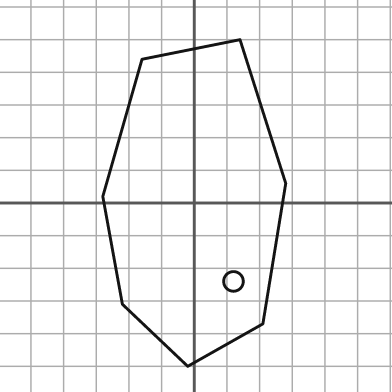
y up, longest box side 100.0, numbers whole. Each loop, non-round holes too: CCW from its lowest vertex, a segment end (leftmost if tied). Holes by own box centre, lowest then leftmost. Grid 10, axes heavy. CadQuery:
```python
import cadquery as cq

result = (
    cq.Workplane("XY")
    .moveTo(-2.0, -50.0)
    .lineTo(21.0, -37.0)
    .lineTo(28.0, 6.0)
    .lineTo(14.0, 50.0)
    .lineTo(-16.0, 44.0)
    .lineTo(-28.0, 2.0)
    .lineTo(-22.0, -31.0)
    .close()
    .moveTo(12.0, -24.0)
    .circle(3.0)
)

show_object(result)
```